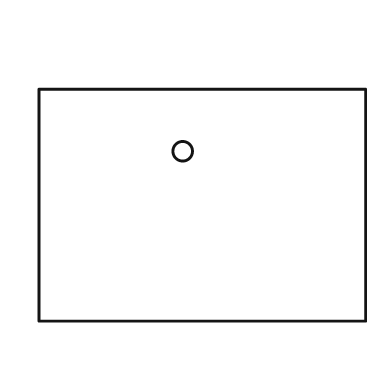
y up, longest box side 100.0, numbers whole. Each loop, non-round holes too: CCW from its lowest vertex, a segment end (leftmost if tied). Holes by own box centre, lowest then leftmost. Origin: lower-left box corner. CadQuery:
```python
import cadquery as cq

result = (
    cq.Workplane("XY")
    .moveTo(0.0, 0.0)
    .lineTo(100.0, 0.0)
    .lineTo(100.0, 71.0)
    .lineTo(0.0, 71.0)
    .close()
    .moveTo(44.0, 52.0)
    .circle(3.0)
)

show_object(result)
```